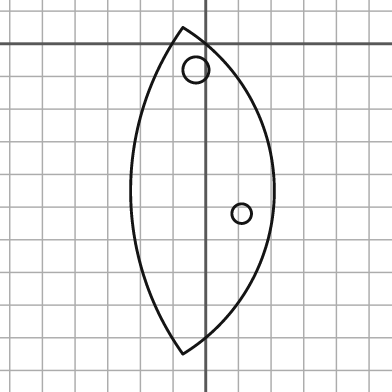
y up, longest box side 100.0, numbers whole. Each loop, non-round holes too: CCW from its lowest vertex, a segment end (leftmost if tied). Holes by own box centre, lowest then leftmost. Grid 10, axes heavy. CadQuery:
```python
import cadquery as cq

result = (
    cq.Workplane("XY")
    .moveTo(-7.0, -95.0)
    .threePointArc((21.0, -45.0), (-7.0, 5.0))
    .threePointArc((-23.0, -45.0), (-7.0, -95.0))
    .close()
    .moveTo(11.0, -52.0)
    .circle(3.0)
    .moveTo(-3.0, -8.0)
    .circle(4.0)
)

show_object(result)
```